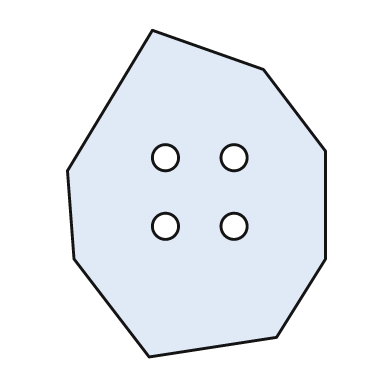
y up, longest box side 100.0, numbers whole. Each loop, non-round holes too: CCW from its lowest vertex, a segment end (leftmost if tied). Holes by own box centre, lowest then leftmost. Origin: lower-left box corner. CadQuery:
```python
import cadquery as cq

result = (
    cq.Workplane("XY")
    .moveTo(25.0, 0.0)
    .lineTo(64.0, 6.0)
    .lineTo(79.0, 30.0)
    .lineTo(79.0, 63.0)
    .lineTo(60.0, 88.0)
    .lineTo(26.0, 100.0)
    .lineTo(0.0, 57.0)
    .lineTo(2.0, 30.0)
    .close()
    .moveTo(30.0, 40.0)
    .circle(4.0)
    .moveTo(51.0, 40.0)
    .circle(4.0)
    .moveTo(30.0, 61.0)
    .circle(4.0)
    .moveTo(51.0, 61.0)
    .circle(4.0)
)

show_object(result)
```